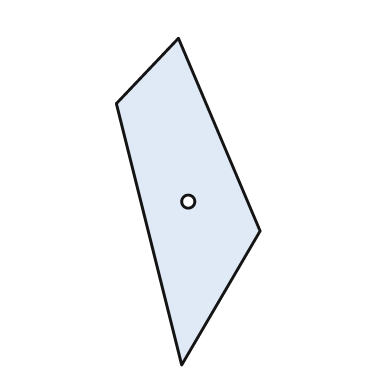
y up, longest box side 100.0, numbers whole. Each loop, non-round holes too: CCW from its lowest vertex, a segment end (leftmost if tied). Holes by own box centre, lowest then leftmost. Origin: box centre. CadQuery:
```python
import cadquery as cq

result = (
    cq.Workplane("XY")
    .moveTo(-2.0, -50.0)
    .lineTo(22.0, -9.0)
    .lineTo(-3.0, 50.0)
    .lineTo(-22.0, 30.0)
    .close()
    .moveTo(0.0, 0.0)
    .circle(2.0)
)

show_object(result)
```